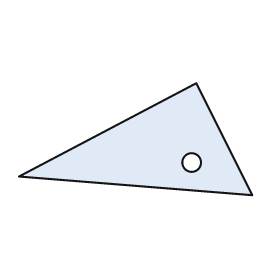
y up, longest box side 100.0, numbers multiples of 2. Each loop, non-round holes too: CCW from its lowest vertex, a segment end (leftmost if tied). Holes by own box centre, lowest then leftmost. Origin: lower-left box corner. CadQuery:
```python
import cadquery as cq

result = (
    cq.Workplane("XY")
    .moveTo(100.0, 0.0)
    .lineTo(76.0, 48.0)
    .lineTo(0.0, 8.0)
    .close()
    .moveTo(74.0, 14.0)
    .circle(4.0)
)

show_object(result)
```